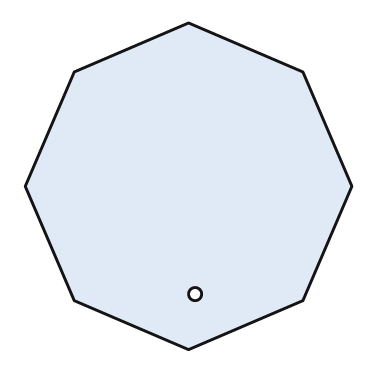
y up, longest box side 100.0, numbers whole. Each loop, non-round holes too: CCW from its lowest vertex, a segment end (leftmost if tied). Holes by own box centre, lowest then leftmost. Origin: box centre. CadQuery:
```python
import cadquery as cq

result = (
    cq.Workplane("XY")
    .moveTo(0.0, -50.0)
    .lineTo(35.0, -35.0)
    .lineTo(50.0, 0.0)
    .lineTo(35.0, 35.0)
    .lineTo(0.0, 50.0)
    .lineTo(-35.0, 35.0)
    .lineTo(-50.0, 0.0)
    .lineTo(-35.0, -35.0)
    .close()
    .moveTo(2.0, -33.0)
    .circle(2.0)
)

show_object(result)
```